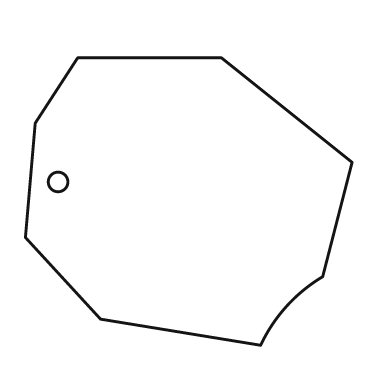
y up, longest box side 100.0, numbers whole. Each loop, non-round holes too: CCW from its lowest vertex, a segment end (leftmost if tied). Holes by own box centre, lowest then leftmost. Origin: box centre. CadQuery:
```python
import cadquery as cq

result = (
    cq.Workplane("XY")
    .moveTo(22.0, -44.0)
    .threePointArc((30.0, -32.0), (41.0, -23.0))
    .lineTo(50.0, 12.0)
    .lineTo(10.0, 44.0)
    .lineTo(-34.0, 44.0)
    .lineTo(-47.0, 24.0)
    .lineTo(-50.0, -11.0)
    .lineTo(-27.0, -36.0)
    .close()
    .moveTo(-40.0, 6.0)
    .circle(3.0)
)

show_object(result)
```